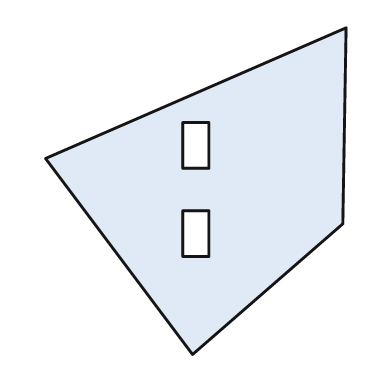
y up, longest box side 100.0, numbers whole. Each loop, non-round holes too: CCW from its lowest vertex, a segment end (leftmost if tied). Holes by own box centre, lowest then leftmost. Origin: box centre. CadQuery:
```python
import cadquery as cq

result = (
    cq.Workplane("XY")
    .moveTo(-1.0, -50.0)
    .lineTo(45.0, -10.0)
    .lineTo(46.0, 50.0)
    .lineTo(-46.0, 10.0)
    .close()
    .moveTo(-4.0, -20.0)
    .lineTo(4.0, -20.0)
    .lineTo(4.0, -6.0)
    .lineTo(-4.0, -6.0)
    .close()
    .moveTo(-4.0, 7.0)
    .lineTo(4.0, 7.0)
    .lineTo(4.0, 21.0)
    .lineTo(-4.0, 21.0)
    .close()
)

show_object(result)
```